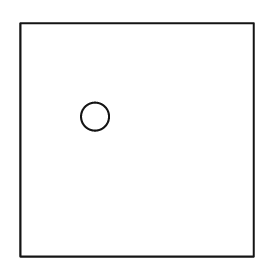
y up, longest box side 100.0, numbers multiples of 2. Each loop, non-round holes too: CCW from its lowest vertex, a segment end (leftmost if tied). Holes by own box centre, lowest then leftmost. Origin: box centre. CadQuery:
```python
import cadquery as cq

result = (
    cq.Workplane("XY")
    .moveTo(-50.0, -50.0)
    .lineTo(50.0, -50.0)
    .lineTo(50.0, 50.0)
    .lineTo(-50.0, 50.0)
    .close()
    .moveTo(-18.0, 10.0)
    .circle(6.0)
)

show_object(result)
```